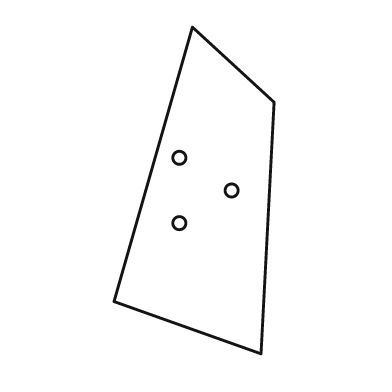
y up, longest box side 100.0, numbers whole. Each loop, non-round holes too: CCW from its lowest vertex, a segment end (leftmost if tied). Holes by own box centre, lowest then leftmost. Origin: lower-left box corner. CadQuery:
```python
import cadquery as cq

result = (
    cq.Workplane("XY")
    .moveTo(45.0, 0.0)
    .lineTo(49.0, 77.0)
    .lineTo(24.0, 100.0)
    .lineTo(0.0, 16.0)
    .close()
    .moveTo(20.0, 40.0)
    .circle(2.0)
    .moveTo(36.0, 50.0)
    .circle(2.0)
    .moveTo(20.0, 60.0)
    .circle(2.0)
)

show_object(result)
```